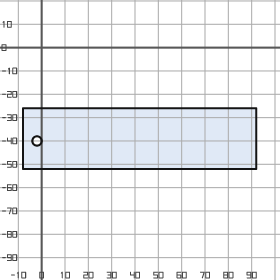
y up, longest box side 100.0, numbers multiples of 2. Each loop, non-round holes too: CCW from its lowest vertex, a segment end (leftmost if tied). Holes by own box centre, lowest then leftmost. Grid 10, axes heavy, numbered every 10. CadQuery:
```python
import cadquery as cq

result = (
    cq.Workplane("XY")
    .moveTo(-8.0, -52.0)
    .lineTo(92.0, -52.0)
    .lineTo(92.0, -26.0)
    .lineTo(-8.0, -26.0)
    .close()
    .moveTo(-2.0, -40.0)
    .circle(2.0)
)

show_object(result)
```